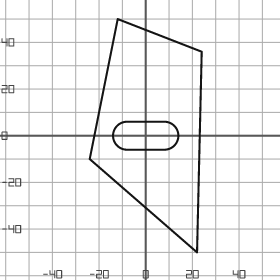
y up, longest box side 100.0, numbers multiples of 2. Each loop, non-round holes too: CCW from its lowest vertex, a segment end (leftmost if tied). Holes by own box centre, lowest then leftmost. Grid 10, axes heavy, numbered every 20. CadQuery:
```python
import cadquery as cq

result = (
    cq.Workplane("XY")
    .moveTo(22.0, -50.0)
    .lineTo(24.0, 36.0)
    .lineTo(-12.0, 50.0)
    .lineTo(-24.0, -10.0)
    .close()
    .moveTo(-8.0, -6.0)
    .lineTo(8.0, -6.0)
    .threePointArc((14.0, 0.0), (8.0, 6.0))
    .lineTo(-8.0, 6.0)
    .threePointArc((-14.0, 0.0), (-8.0, -6.0))
    .close()
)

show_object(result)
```